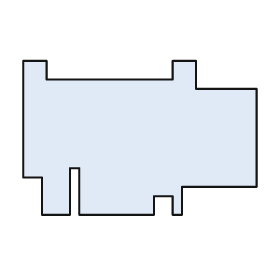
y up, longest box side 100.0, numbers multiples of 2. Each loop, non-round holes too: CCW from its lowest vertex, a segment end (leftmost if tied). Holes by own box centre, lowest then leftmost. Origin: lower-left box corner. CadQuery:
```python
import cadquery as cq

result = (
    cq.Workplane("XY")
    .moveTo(8.0, 0.0)
    .lineTo(20.0, 0.0)
    .lineTo(20.0, 20.0)
    .lineTo(24.0, 20.0)
    .lineTo(24.0, 0.0)
    .lineTo(56.0, 0.0)
    .lineTo(56.0, 8.0)
    .lineTo(64.0, 8.0)
    .lineTo(64.0, 0.0)
    .lineTo(68.0, 0.0)
    .lineTo(68.0, 12.0)
    .lineTo(100.0, 12.0)
    .lineTo(100.0, 54.0)
    .lineTo(74.0, 54.0)
    .lineTo(74.0, 66.0)
    .lineTo(64.0, 66.0)
    .lineTo(64.0, 58.0)
    .lineTo(10.0, 58.0)
    .lineTo(10.0, 66.0)
    .lineTo(0.0, 66.0)
    .lineTo(0.0, 16.0)
    .lineTo(8.0, 16.0)
    .close()
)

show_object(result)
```